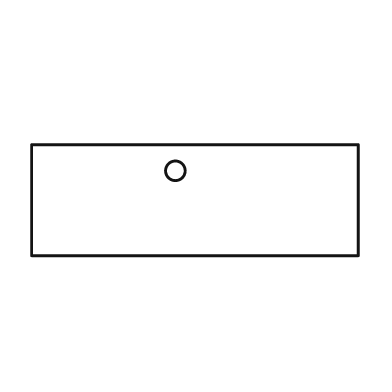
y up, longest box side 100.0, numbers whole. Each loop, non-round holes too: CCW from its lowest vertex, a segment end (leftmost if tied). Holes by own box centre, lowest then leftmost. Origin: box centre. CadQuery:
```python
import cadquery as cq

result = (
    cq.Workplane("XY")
    .moveTo(-50.0, -17.0)
    .lineTo(50.0, -17.0)
    .lineTo(50.0, 17.0)
    .lineTo(-50.0, 17.0)
    .close()
    .moveTo(-6.0, 9.0)
    .circle(3.0)
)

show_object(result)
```